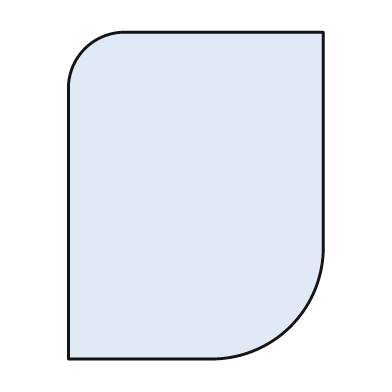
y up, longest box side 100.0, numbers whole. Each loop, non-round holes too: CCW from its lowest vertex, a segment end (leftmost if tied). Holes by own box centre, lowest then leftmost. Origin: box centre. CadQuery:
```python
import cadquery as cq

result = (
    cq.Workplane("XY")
    .moveTo(-39.0, -50.0)
    .lineTo(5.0, -50.0)
    .threePointArc((29.0, -40.0), (39.0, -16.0))
    .lineTo(39.0, 50.0)
    .lineTo(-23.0, 50.0)
    .threePointArc((-34.0, 45.0), (-39.0, 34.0))
    .close()
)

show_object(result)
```